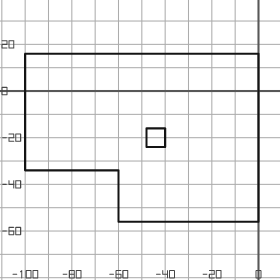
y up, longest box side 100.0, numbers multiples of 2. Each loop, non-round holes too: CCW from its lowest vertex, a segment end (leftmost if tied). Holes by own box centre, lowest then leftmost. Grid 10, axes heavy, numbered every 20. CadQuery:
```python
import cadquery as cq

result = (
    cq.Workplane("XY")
    .moveTo(-60.0, -56.0)
    .lineTo(0.0, -56.0)
    .lineTo(0.0, 16.0)
    .lineTo(-100.0, 16.0)
    .lineTo(-100.0, -34.0)
    .lineTo(-60.0, -34.0)
    .close()
    .moveTo(-48.0, -24.0)
    .lineTo(-40.0, -24.0)
    .lineTo(-40.0, -16.0)
    .lineTo(-48.0, -16.0)
    .close()
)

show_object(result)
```